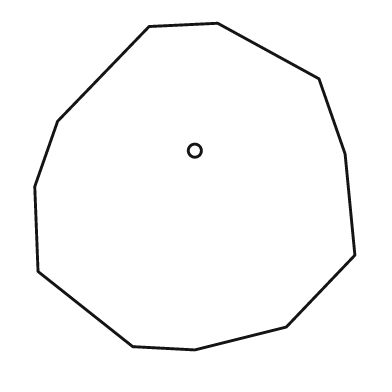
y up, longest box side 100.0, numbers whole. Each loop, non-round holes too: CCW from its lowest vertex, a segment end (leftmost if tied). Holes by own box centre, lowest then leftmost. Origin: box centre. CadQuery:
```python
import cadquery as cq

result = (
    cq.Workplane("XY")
    .moveTo(0.0, -50.0)
    .lineTo(28.0, -43.0)
    .lineTo(49.0, -21.0)
    .lineTo(46.0, 10.0)
    .lineTo(38.0, 33.0)
    .lineTo(7.0, 50.0)
    .lineTo(-14.0, 49.0)
    .lineTo(-42.0, 20.0)
    .lineTo(-49.0, 0.0)
    .lineTo(-48.0, -26.0)
    .lineTo(-19.0, -49.0)
    .close()
    .moveTo(0.0, 11.0)
    .circle(2.0)
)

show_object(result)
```